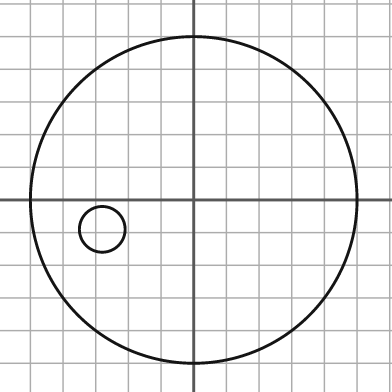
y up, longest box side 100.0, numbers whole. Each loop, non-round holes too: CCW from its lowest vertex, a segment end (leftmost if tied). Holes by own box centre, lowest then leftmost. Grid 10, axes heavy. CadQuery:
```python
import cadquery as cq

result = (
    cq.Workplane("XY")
    .moveTo(0.0, 0.0)
    .circle(50.0)
    .moveTo(-28.0, -9.0)
    .circle(7.0)
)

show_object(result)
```